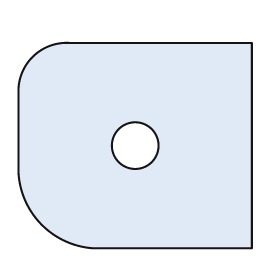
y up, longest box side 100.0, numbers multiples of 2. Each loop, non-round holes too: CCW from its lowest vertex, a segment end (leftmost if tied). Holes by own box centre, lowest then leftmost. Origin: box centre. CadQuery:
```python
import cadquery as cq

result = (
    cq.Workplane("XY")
    .moveTo(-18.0, -44.0)
    .lineTo(50.0, -44.0)
    .lineTo(50.0, 44.0)
    .lineTo(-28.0, 44.0)
    .threePointArc((-44.0, 38.0), (-50.0, 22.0))
    .lineTo(-50.0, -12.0)
    .threePointArc((-40.0, -34.0), (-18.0, -44.0))
    .close()
    .moveTo(0.0, 0.0)
    .circle(10.0)
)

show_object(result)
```